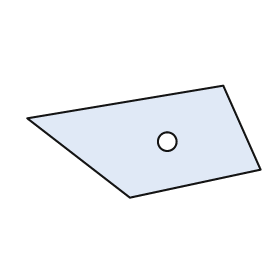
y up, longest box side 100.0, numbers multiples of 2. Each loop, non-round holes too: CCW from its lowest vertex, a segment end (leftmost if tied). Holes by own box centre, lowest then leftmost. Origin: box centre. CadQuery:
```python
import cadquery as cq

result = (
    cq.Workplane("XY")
    .moveTo(-6.0, -24.0)
    .lineTo(50.0, -12.0)
    .lineTo(34.0, 24.0)
    .lineTo(-50.0, 10.0)
    .close()
    .moveTo(10.0, 0.0)
    .circle(4.0)
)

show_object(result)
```